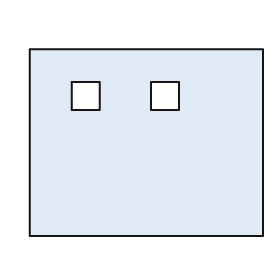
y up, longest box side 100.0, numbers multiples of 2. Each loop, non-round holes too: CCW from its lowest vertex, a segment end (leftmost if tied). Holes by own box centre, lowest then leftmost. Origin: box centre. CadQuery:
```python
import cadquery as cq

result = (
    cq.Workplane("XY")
    .moveTo(-50.0, -40.0)
    .lineTo(50.0, -40.0)
    .lineTo(50.0, 40.0)
    .lineTo(-50.0, 40.0)
    .close()
    .moveTo(-32.0, 14.0)
    .lineTo(-20.0, 14.0)
    .lineTo(-20.0, 26.0)
    .lineTo(-32.0, 26.0)
    .close()
    .moveTo(2.0, 14.0)
    .lineTo(14.0, 14.0)
    .lineTo(14.0, 26.0)
    .lineTo(2.0, 26.0)
    .close()
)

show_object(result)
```